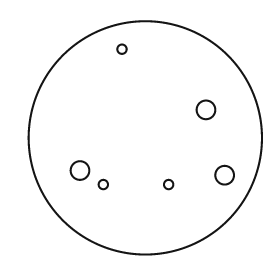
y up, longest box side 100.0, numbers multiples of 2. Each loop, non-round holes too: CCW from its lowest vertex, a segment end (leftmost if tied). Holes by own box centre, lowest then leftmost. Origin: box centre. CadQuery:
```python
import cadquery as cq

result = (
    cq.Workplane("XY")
    .moveTo(0.0, 0.0)
    .circle(50.0)
    .moveTo(-18.0, -20.0)
    .circle(2.0)
    .moveTo(10.0, -20.0)
    .circle(2.0)
    .moveTo(34.0, -16.0)
    .circle(4.0)
    .moveTo(-28.0, -14.0)
    .circle(4.0)
    .moveTo(26.0, 12.0)
    .circle(4.0)
    .moveTo(-10.0, 38.0)
    .circle(2.0)
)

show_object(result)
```